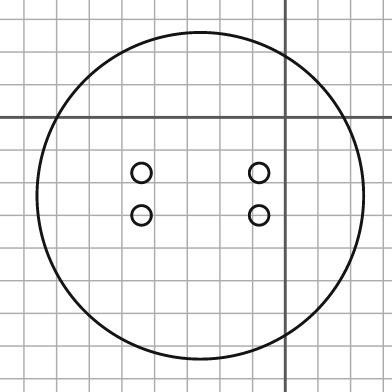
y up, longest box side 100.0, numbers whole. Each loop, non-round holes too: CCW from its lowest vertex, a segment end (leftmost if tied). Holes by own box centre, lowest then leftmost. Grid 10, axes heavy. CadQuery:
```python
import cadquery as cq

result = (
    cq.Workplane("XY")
    .moveTo(-26.0, -24.0)
    .circle(50.0)
    .moveTo(-44.0, -30.0)
    .circle(3.0)
    .moveTo(-8.0, -30.0)
    .circle(3.0)
    .moveTo(-44.0, -17.0)
    .circle(3.0)
    .moveTo(-8.0, -17.0)
    .circle(3.0)
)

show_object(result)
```